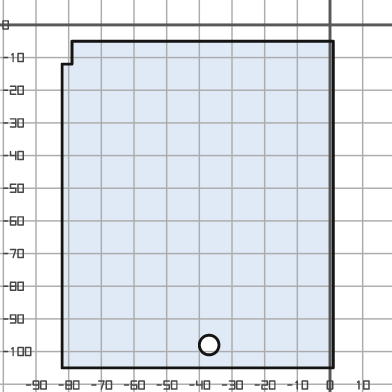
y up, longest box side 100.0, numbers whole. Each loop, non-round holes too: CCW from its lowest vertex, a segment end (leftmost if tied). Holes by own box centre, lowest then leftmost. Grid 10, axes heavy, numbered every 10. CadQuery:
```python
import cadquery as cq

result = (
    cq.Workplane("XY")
    .moveTo(-82.0, -105.0)
    .lineTo(1.0, -105.0)
    .lineTo(1.0, -5.0)
    .lineTo(-79.0, -5.0)
    .lineTo(-79.0, -12.0)
    .lineTo(-82.0, -12.0)
    .close()
    .moveTo(-37.0, -98.0)
    .circle(3.0)
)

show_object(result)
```